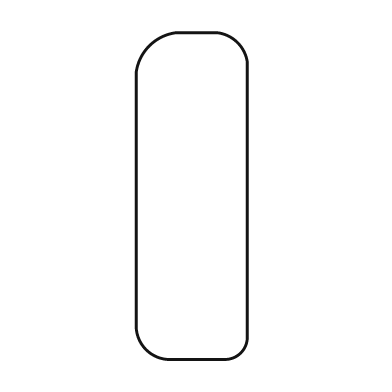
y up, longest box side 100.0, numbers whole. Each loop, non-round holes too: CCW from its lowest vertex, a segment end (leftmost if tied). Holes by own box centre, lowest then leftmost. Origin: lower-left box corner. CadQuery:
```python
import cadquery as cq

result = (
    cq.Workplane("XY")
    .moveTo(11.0, 0.0)
    .lineTo(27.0, 0.0)
    .threePointArc((32.0, 2.0), (34.0, 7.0))
    .lineTo(34.0, 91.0)
    .threePointArc((31.0, 97.0), (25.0, 100.0))
    .lineTo(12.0, 100.0)
    .threePointArc((4.0, 96.0), (0.0, 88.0))
    .lineTo(0.0, 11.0)
    .threePointArc((3.0, 3.0), (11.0, 0.0))
    .close()
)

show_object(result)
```